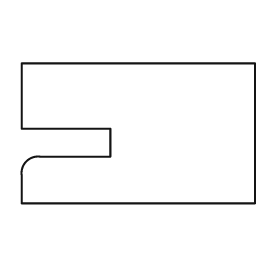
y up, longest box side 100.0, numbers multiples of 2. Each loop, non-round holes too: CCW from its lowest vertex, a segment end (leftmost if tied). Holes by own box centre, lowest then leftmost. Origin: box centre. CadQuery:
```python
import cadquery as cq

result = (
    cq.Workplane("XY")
    .moveTo(-50.0, -30.0)
    .lineTo(50.0, -30.0)
    .lineTo(50.0, 30.0)
    .lineTo(-50.0, 30.0)
    .lineTo(-50.0, 2.0)
    .lineTo(-12.0, 2.0)
    .lineTo(-12.0, -10.0)
    .lineTo(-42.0, -10.0)
    .threePointArc((-48.0, -12.0), (-50.0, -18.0))
    .close()
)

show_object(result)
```